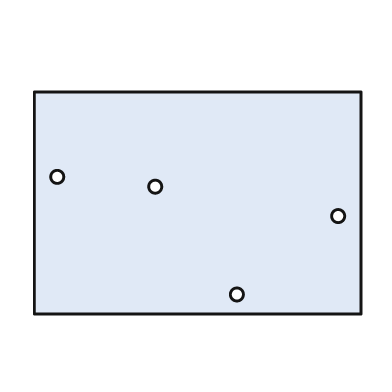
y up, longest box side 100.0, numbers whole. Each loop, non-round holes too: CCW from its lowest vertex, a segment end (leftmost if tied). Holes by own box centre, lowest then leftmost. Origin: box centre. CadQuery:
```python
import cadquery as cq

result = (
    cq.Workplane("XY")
    .moveTo(-50.0, -34.0)
    .lineTo(50.0, -34.0)
    .lineTo(50.0, 34.0)
    .lineTo(-50.0, 34.0)
    .close()
    .moveTo(12.0, -28.0)
    .circle(2.0)
    .moveTo(43.0, -4.0)
    .circle(2.0)
    .moveTo(-13.0, 5.0)
    .circle(2.0)
    .moveTo(-43.0, 8.0)
    .circle(2.0)
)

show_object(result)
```